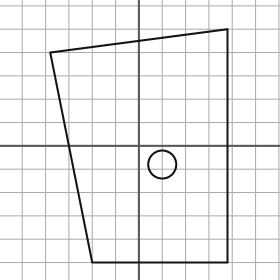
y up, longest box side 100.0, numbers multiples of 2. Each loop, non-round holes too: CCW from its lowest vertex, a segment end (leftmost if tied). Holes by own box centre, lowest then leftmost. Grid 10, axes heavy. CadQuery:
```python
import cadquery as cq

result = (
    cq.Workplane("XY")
    .moveTo(-20.0, -50.0)
    .lineTo(38.0, -50.0)
    .lineTo(38.0, 50.0)
    .lineTo(-38.0, 40.0)
    .close()
    .moveTo(10.0, -8.0)
    .circle(6.0)
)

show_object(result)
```